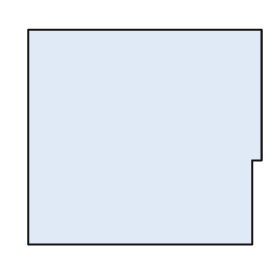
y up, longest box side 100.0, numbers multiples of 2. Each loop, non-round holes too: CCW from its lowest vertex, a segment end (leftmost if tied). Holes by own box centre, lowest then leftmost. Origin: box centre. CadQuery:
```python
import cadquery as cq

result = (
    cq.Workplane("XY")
    .moveTo(-50.0, -46.0)
    .lineTo(46.0, -46.0)
    .lineTo(46.0, -10.0)
    .lineTo(50.0, -10.0)
    .lineTo(50.0, 46.0)
    .lineTo(-50.0, 46.0)
    .close()
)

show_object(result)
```